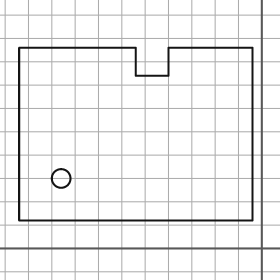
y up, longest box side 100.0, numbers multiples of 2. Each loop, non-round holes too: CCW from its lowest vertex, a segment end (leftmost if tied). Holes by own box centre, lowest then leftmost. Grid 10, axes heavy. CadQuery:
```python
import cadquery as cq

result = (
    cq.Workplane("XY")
    .moveTo(-104.0, 12.0)
    .lineTo(-4.0, 12.0)
    .lineTo(-4.0, 86.0)
    .lineTo(-40.0, 86.0)
    .lineTo(-40.0, 74.0)
    .lineTo(-54.0, 74.0)
    .lineTo(-54.0, 86.0)
    .lineTo(-104.0, 86.0)
    .close()
    .moveTo(-86.0, 30.0)
    .circle(4.0)
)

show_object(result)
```